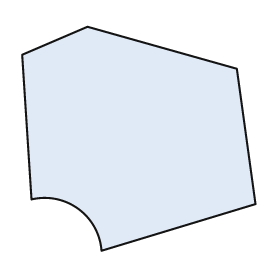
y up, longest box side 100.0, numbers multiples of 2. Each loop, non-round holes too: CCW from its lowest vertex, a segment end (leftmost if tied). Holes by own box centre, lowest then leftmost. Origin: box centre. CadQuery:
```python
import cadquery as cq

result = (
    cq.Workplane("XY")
    .moveTo(-16.0, -48.0)
    .lineTo(50.0, -28.0)
    .lineTo(42.0, 30.0)
    .lineTo(-22.0, 48.0)
    .lineTo(-50.0, 36.0)
    .lineTo(-46.0, -26.0)
    .threePointArc((-26.0, -30.0), (-16.0, -48.0))
    .close()
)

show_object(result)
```